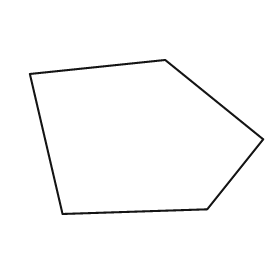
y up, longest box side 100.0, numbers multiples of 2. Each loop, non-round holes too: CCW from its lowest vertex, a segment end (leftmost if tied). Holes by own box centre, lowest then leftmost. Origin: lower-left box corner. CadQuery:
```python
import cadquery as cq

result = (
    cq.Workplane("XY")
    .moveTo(14.0, 0.0)
    .lineTo(76.0, 2.0)
    .lineTo(100.0, 32.0)
    .lineTo(58.0, 66.0)
    .lineTo(0.0, 60.0)
    .close()
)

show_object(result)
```